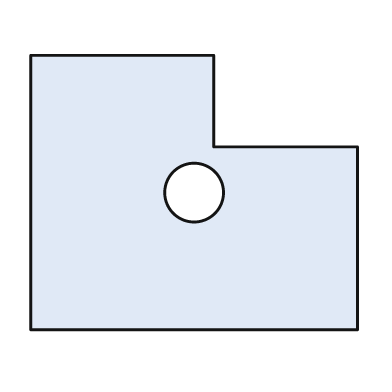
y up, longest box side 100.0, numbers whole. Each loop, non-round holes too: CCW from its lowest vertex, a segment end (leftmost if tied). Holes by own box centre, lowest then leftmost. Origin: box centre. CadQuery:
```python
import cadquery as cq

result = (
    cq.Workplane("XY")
    .moveTo(-50.0, -42.0)
    .lineTo(50.0, -42.0)
    .lineTo(50.0, 14.0)
    .lineTo(6.0, 14.0)
    .lineTo(6.0, 42.0)
    .lineTo(-50.0, 42.0)
    .close()
    .moveTo(0.0, 0.0)
    .circle(9.0)
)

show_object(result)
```